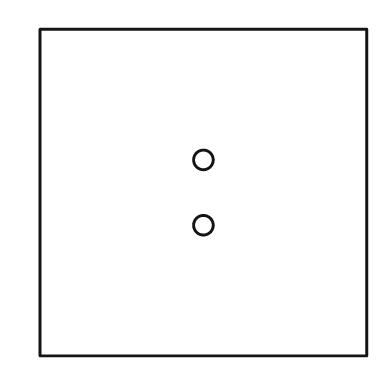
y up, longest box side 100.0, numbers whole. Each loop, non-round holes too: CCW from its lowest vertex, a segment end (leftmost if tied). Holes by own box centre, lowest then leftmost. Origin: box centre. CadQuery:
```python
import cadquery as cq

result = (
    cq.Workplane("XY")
    .moveTo(-50.0, -50.0)
    .lineTo(50.0, -50.0)
    .lineTo(50.0, 50.0)
    .lineTo(-50.0, 50.0)
    .close()
    .moveTo(0.0, -10.0)
    .circle(3.0)
    .moveTo(0.0, 10.0)
    .circle(3.0)
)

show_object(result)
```